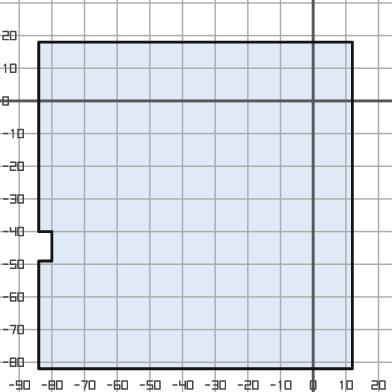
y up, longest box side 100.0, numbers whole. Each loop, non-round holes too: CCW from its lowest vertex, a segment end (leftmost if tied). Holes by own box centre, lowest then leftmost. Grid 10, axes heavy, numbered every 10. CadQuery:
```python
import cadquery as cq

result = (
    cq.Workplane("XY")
    .moveTo(-84.0, -82.0)
    .lineTo(12.0, -82.0)
    .lineTo(12.0, 18.0)
    .lineTo(-84.0, 18.0)
    .lineTo(-84.0, -40.0)
    .lineTo(-80.0, -40.0)
    .lineTo(-80.0, -49.0)
    .lineTo(-84.0, -49.0)
    .close()
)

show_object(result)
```